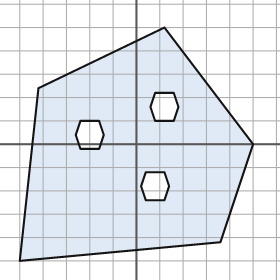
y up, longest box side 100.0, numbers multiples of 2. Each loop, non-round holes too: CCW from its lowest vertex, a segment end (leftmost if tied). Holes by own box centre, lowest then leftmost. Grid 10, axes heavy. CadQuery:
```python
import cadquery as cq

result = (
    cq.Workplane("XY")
    .moveTo(-50.0, -50.0)
    .lineTo(36.0, -42.0)
    .lineTo(50.0, 0.0)
    .lineTo(12.0, 50.0)
    .lineTo(-42.0, 24.0)
    .close()
    .moveTo(4.0, -24.0)
    .lineTo(12.0, -24.0)
    .lineTo(14.0, -18.0)
    .lineTo(12.0, -12.0)
    .lineTo(4.0, -12.0)
    .lineTo(2.0, -18.0)
    .close()
    .moveTo(-24.0, -2.0)
    .lineTo(-16.0, -2.0)
    .lineTo(-14.0, 4.0)
    .lineTo(-16.0, 10.0)
    .lineTo(-24.0, 10.0)
    .lineTo(-26.0, 4.0)
    .close()
    .moveTo(8.0, 10.0)
    .lineTo(16.0, 10.0)
    .lineTo(18.0, 16.0)
    .lineTo(16.0, 22.0)
    .lineTo(8.0, 22.0)
    .lineTo(6.0, 16.0)
    .close()
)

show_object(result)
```